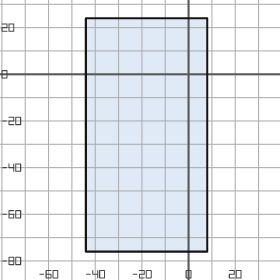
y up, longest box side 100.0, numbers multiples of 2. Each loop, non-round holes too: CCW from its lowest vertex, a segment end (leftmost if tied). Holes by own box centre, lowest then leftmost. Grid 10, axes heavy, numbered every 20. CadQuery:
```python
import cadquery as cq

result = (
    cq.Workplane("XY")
    .moveTo(-44.0, -76.0)
    .lineTo(8.0, -76.0)
    .lineTo(8.0, 24.0)
    .lineTo(-44.0, 24.0)
    .close()
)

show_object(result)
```